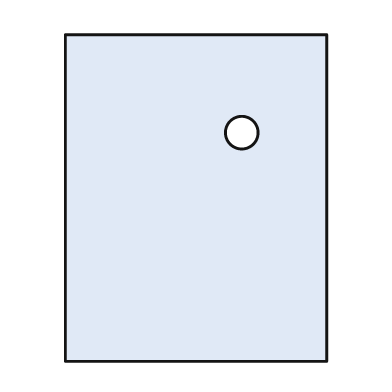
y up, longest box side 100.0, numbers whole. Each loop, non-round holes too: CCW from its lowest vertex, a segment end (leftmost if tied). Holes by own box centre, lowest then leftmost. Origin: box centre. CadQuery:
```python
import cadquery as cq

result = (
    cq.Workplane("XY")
    .moveTo(-40.0, -50.0)
    .lineTo(40.0, -50.0)
    .lineTo(40.0, 50.0)
    .lineTo(-40.0, 50.0)
    .close()
    .moveTo(14.0, 20.0)
    .circle(5.0)
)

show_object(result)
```